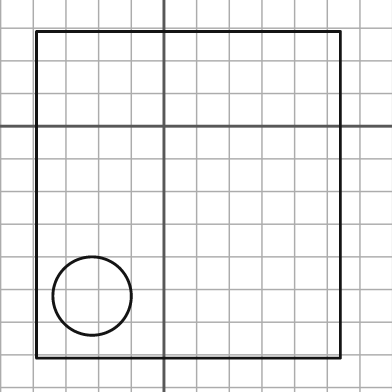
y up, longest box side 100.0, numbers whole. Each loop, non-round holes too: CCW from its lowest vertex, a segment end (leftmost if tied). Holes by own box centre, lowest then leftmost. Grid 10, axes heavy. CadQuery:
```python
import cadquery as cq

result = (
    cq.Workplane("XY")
    .moveTo(-39.0, -71.0)
    .lineTo(54.0, -71.0)
    .lineTo(54.0, 29.0)
    .lineTo(-39.0, 29.0)
    .close()
    .moveTo(-22.0, -52.0)
    .circle(12.0)
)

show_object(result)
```